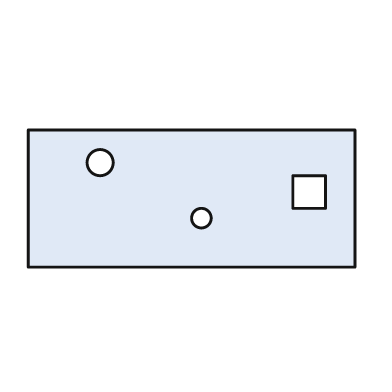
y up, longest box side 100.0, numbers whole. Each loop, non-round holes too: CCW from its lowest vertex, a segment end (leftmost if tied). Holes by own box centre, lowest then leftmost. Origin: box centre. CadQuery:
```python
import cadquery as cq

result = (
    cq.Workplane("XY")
    .moveTo(-50.0, -21.0)
    .lineTo(50.0, -21.0)
    .lineTo(50.0, 21.0)
    .lineTo(-50.0, 21.0)
    .close()
    .moveTo(3.0, -6.0)
    .circle(3.0)
    .moveTo(31.0, -3.0)
    .lineTo(41.0, -3.0)
    .lineTo(41.0, 7.0)
    .lineTo(31.0, 7.0)
    .close()
    .moveTo(-28.0, 11.0)
    .circle(4.0)
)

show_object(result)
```